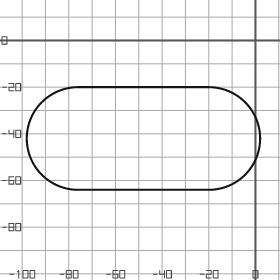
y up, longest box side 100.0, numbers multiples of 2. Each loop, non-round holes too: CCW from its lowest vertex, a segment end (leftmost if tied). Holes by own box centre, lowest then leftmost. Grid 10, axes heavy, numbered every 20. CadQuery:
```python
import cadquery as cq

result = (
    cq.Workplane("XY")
    .moveTo(-76.0, -64.0)
    .lineTo(-20.0, -64.0)
    .threePointArc((2.0, -42.0), (-20.0, -20.0))
    .lineTo(-76.0, -20.0)
    .threePointArc((-98.0, -42.0), (-76.0, -64.0))
    .close()
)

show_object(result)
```